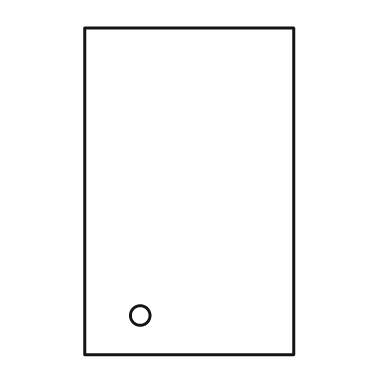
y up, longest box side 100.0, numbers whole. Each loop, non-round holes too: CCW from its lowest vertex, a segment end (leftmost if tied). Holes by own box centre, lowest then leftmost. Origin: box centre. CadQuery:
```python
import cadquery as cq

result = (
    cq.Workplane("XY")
    .moveTo(-32.0, -50.0)
    .lineTo(32.0, -50.0)
    .lineTo(32.0, 50.0)
    .lineTo(-32.0, 50.0)
    .close()
    .moveTo(-15.0, -38.0)
    .circle(3.0)
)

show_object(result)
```